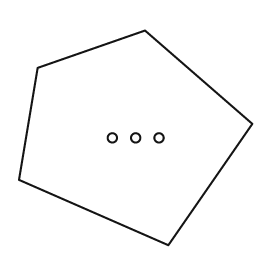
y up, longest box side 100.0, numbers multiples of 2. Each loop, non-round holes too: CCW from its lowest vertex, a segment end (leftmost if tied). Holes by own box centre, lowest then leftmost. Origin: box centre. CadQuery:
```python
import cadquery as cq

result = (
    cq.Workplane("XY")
    .moveTo(14.0, -46.0)
    .lineTo(50.0, 6.0)
    .lineTo(4.0, 46.0)
    .lineTo(-42.0, 30.0)
    .lineTo(-50.0, -18.0)
    .close()
    .moveTo(-10.0, 0.0)
    .circle(2.0)
    .moveTo(0.0, 0.0)
    .circle(2.0)
    .moveTo(10.0, 0.0)
    .circle(2.0)
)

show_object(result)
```